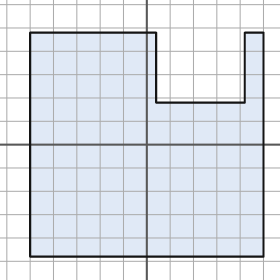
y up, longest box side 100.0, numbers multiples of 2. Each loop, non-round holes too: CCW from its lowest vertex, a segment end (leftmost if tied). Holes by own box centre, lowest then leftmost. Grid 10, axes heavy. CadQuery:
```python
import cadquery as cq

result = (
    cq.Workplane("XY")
    .moveTo(-50.0, -48.0)
    .lineTo(50.0, -48.0)
    .lineTo(50.0, 48.0)
    .lineTo(42.0, 48.0)
    .lineTo(42.0, 18.0)
    .lineTo(4.0, 18.0)
    .lineTo(4.0, 48.0)
    .lineTo(-50.0, 48.0)
    .close()
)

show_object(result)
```